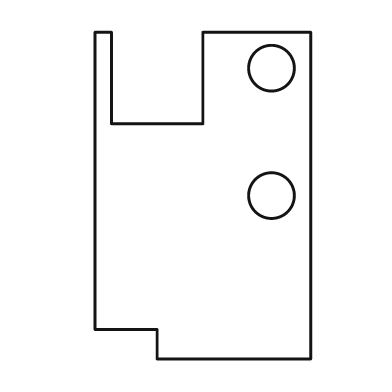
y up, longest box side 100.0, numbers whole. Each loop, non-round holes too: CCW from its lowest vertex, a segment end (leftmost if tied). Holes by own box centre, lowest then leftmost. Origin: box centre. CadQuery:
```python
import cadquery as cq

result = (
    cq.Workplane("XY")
    .moveTo(-14.0, -50.0)
    .lineTo(33.0, -50.0)
    .lineTo(33.0, 50.0)
    .lineTo(0.0, 50.0)
    .lineTo(0.0, 22.0)
    .lineTo(-28.0, 22.0)
    .lineTo(-28.0, 50.0)
    .lineTo(-33.0, 50.0)
    .lineTo(-33.0, -41.0)
    .lineTo(-14.0, -41.0)
    .close()
    .moveTo(21.0, 0.0)
    .circle(7.0)
    .moveTo(21.0, 39.0)
    .circle(7.0)
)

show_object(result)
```